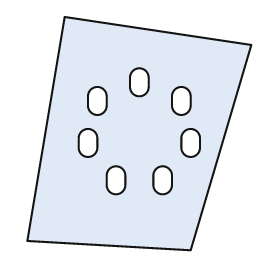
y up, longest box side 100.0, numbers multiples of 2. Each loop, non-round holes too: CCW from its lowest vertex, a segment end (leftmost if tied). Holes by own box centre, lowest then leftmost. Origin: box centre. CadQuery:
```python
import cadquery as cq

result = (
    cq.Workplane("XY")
    .moveTo(22.0, -50.0)
    .lineTo(48.0, 38.0)
    .lineTo(-32.0, 50.0)
    .lineTo(-48.0, -46.0)
    .close()
    .moveTo(-14.0, -22.0)
    .threePointArc((-10.0, -26.0), (-6.0, -22.0))
    .lineTo(-6.0, -18.0)
    .threePointArc((-10.0, -14.0), (-14.0, -18.0))
    .close()
    .moveTo(6.0, -22.0)
    .threePointArc((10.0, -26.0), (14.0, -22.0))
    .lineTo(14.0, -18.0)
    .threePointArc((10.0, -14.0), (6.0, -18.0))
    .close()
    .moveTo(-26.0, -6.0)
    .threePointArc((-22.0, -10.0), (-18.0, -6.0))
    .lineTo(-18.0, -2.0)
    .threePointArc((-22.0, 2.0), (-26.0, -2.0))
    .close()
    .moveTo(18.0, -6.0)
    .threePointArc((22.0, -10.0), (26.0, -6.0))
    .lineTo(26.0, -2.0)
    .threePointArc((22.0, 2.0), (18.0, -2.0))
    .close()
    .moveTo(-22.0, 12.0)
    .threePointArc((-18.0, 8.0), (-14.0, 12.0))
    .lineTo(-14.0, 16.0)
    .threePointArc((-18.0, 20.0), (-22.0, 16.0))
    .close()
    .moveTo(14.0, 12.0)
    .threePointArc((18.0, 8.0), (22.0, 12.0))
    .lineTo(22.0, 16.0)
    .threePointArc((18.0, 20.0), (14.0, 16.0))
    .close()
    .moveTo(-4.0, 20.0)
    .threePointArc((0.0, 16.0), (4.0, 20.0))
    .lineTo(4.0, 24.0)
    .threePointArc((0.0, 28.0), (-4.0, 24.0))
    .close()
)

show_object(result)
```